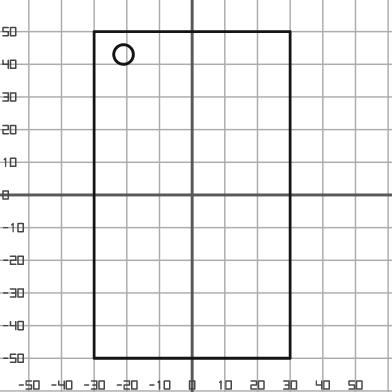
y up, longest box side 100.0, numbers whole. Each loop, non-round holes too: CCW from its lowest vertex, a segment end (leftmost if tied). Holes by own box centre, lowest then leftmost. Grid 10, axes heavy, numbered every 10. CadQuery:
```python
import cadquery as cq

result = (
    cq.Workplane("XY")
    .moveTo(-30.0, -50.0)
    .lineTo(30.0, -50.0)
    .lineTo(30.0, 50.0)
    .lineTo(-30.0, 50.0)
    .close()
    .moveTo(-21.0, 43.0)
    .circle(3.0)
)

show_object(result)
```